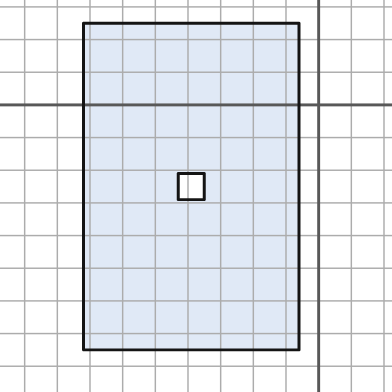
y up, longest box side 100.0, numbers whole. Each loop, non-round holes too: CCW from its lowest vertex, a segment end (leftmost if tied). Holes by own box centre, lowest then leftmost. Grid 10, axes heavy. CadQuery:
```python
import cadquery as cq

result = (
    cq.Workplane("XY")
    .moveTo(-72.0, -75.0)
    .lineTo(-6.0, -75.0)
    .lineTo(-6.0, 25.0)
    .lineTo(-72.0, 25.0)
    .close()
    .moveTo(-43.0, -29.0)
    .lineTo(-35.0, -29.0)
    .lineTo(-35.0, -21.0)
    .lineTo(-43.0, -21.0)
    .close()
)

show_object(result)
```